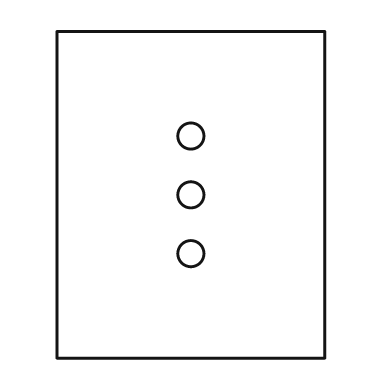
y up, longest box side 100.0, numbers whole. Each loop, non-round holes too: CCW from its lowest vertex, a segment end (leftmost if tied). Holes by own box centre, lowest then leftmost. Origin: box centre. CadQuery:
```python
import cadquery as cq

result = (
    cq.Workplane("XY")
    .moveTo(-41.0, -50.0)
    .lineTo(41.0, -50.0)
    .lineTo(41.0, 50.0)
    .lineTo(-41.0, 50.0)
    .close()
    .moveTo(0.0, -18.0)
    .circle(4.0)
    .moveTo(0.0, 0.0)
    .circle(4.0)
    .moveTo(0.0, 18.0)
    .circle(4.0)
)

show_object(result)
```